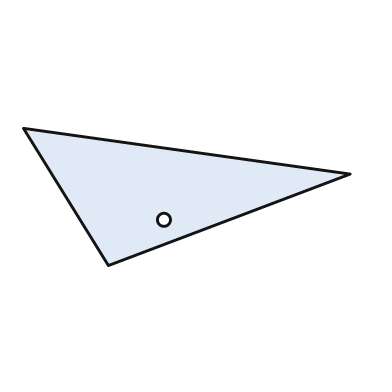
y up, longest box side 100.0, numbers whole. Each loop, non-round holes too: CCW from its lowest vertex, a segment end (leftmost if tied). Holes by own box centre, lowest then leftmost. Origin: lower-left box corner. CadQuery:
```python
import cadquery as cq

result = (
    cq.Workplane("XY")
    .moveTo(26.0, 0.0)
    .lineTo(100.0, 28.0)
    .lineTo(0.0, 42.0)
    .close()
    .moveTo(43.0, 14.0)
    .circle(2.0)
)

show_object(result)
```